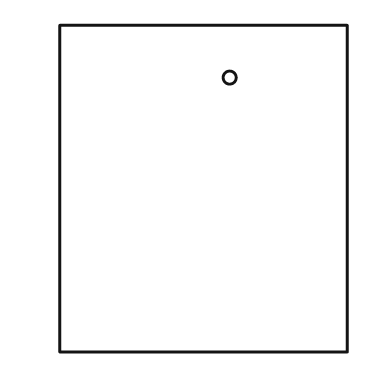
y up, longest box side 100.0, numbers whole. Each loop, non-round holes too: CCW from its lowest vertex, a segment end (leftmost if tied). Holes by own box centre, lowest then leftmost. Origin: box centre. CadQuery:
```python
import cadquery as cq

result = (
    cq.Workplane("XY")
    .moveTo(-44.0, -50.0)
    .lineTo(44.0, -50.0)
    .lineTo(44.0, 50.0)
    .lineTo(-44.0, 50.0)
    .close()
    .moveTo(8.0, 34.0)
    .circle(2.0)
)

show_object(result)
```